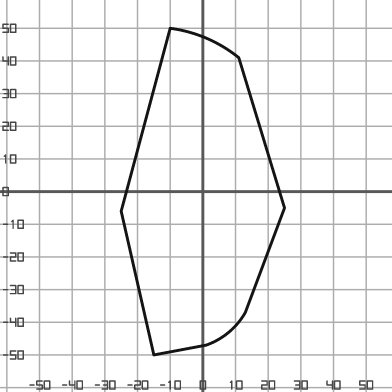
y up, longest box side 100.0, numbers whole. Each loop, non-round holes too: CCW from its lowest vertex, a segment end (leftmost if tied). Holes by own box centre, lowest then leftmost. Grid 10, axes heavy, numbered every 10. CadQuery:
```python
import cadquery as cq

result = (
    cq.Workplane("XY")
    .moveTo(-15.0, -50.0)
    .lineTo(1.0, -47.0)
    .threePointArc((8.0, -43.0), (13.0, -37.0))
    .lineTo(25.0, -5.0)
    .lineTo(11.0, 41.0)
    .threePointArc((1.0, 47.0), (-10.0, 50.0))
    .lineTo(-25.0, -6.0)
    .close()
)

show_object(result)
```